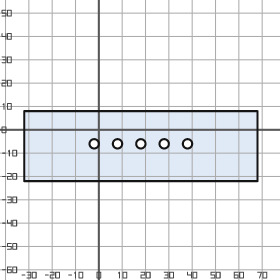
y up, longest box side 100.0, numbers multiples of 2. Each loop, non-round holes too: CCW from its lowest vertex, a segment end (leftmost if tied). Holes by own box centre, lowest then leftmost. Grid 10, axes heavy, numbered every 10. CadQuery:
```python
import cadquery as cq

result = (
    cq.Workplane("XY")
    .moveTo(-32.0, -22.0)
    .lineTo(68.0, -22.0)
    .lineTo(68.0, 8.0)
    .lineTo(-32.0, 8.0)
    .close()
    .moveTo(-2.0, -6.0)
    .circle(2.0)
    .moveTo(8.0, -6.0)
    .circle(2.0)
    .moveTo(18.0, -6.0)
    .circle(2.0)
    .moveTo(28.0, -6.0)
    .circle(2.0)
    .moveTo(38.0, -6.0)
    .circle(2.0)
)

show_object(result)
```